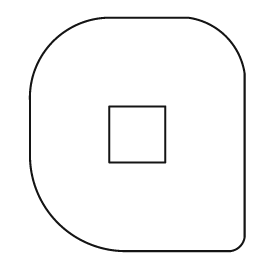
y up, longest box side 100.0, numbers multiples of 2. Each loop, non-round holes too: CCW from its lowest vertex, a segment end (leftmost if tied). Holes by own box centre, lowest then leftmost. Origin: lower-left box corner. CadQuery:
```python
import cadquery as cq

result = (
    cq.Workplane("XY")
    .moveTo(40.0, 0.0)
    .lineTo(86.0, 0.0)
    .threePointArc((90.0, 2.0), (92.0, 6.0))
    .lineTo(92.0, 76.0)
    .threePointArc((84.0, 92.0), (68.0, 100.0))
    .lineTo(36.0, 100.0)
    .threePointArc((10.0, 90.0), (0.0, 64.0))
    .lineTo(0.0, 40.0)
    .threePointArc((12.0, 12.0), (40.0, 0.0))
    .close()
    .moveTo(34.0, 38.0)
    .lineTo(58.0, 38.0)
    .lineTo(58.0, 62.0)
    .lineTo(34.0, 62.0)
    .close()
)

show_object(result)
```